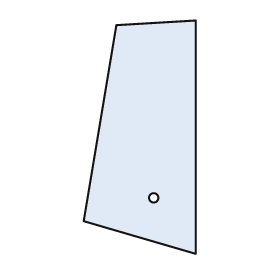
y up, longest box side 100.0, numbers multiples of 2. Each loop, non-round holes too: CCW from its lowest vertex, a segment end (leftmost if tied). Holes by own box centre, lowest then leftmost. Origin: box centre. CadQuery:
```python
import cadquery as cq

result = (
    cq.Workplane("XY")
    .moveTo(24.0, -50.0)
    .lineTo(24.0, 50.0)
    .lineTo(-10.0, 48.0)
    .lineTo(-24.0, -36.0)
    .close()
    .moveTo(6.0, -26.0)
    .circle(2.0)
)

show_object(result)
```